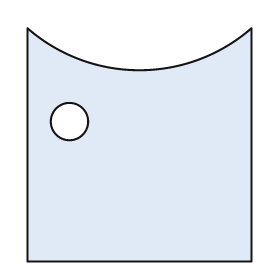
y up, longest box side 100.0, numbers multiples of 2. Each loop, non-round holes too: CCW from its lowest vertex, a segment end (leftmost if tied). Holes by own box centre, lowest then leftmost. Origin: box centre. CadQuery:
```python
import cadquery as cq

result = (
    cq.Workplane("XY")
    .moveTo(-48.0, -50.0)
    .lineTo(48.0, -50.0)
    .lineTo(48.0, 50.0)
    .threePointArc((0.0, 32.0), (-48.0, 50.0))
    .close()
    .moveTo(-30.0, 10.0)
    .circle(8.0)
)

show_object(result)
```